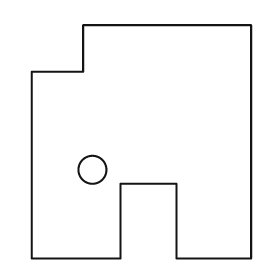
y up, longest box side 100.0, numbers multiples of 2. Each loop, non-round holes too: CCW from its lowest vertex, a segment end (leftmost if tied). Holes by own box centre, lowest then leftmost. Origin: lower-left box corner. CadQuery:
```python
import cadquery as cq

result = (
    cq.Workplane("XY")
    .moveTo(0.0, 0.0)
    .lineTo(38.0, 0.0)
    .lineTo(38.0, 32.0)
    .lineTo(62.0, 32.0)
    .lineTo(62.0, 0.0)
    .lineTo(94.0, 0.0)
    .lineTo(94.0, 100.0)
    .lineTo(22.0, 100.0)
    .lineTo(22.0, 80.0)
    .lineTo(0.0, 80.0)
    .close()
    .moveTo(26.0, 38.0)
    .circle(6.0)
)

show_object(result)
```